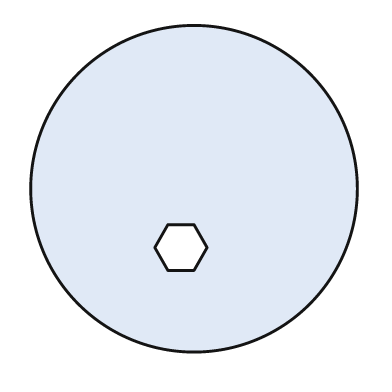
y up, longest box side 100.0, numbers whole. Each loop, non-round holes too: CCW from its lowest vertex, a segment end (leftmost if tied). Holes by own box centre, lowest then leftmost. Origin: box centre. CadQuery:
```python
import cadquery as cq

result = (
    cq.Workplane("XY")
    .moveTo(0.0, 0.0)
    .circle(50.0)
    .moveTo(-8.0, -25.0)
    .lineTo(0.0, -25.0)
    .lineTo(4.0, -18.0)
    .lineTo(0.0, -11.0)
    .lineTo(-8.0, -11.0)
    .lineTo(-12.0, -18.0)
    .close()
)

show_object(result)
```